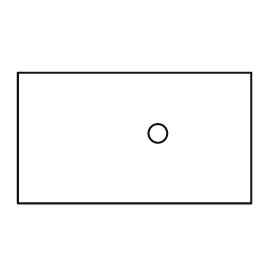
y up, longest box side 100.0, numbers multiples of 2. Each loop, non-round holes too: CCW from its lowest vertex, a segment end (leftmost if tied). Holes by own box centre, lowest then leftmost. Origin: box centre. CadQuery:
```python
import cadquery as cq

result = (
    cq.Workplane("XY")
    .moveTo(-50.0, -28.0)
    .lineTo(50.0, -28.0)
    .lineTo(50.0, 28.0)
    .lineTo(-50.0, 28.0)
    .close()
    .moveTo(10.0, 2.0)
    .circle(4.0)
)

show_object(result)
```